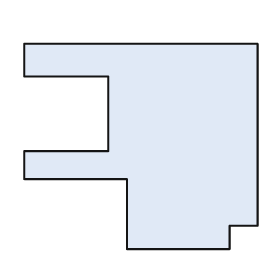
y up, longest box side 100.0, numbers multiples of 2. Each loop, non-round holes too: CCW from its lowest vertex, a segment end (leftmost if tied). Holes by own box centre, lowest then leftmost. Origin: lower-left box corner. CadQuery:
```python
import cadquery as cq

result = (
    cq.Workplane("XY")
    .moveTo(44.0, 0.0)
    .lineTo(88.0, 0.0)
    .lineTo(88.0, 10.0)
    .lineTo(100.0, 10.0)
    .lineTo(100.0, 88.0)
    .lineTo(0.0, 88.0)
    .lineTo(0.0, 74.0)
    .lineTo(36.0, 74.0)
    .lineTo(36.0, 42.0)
    .lineTo(0.0, 42.0)
    .lineTo(0.0, 30.0)
    .lineTo(44.0, 30.0)
    .close()
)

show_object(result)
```